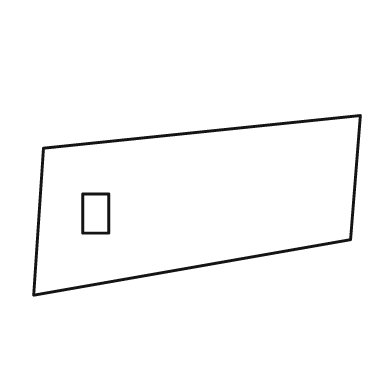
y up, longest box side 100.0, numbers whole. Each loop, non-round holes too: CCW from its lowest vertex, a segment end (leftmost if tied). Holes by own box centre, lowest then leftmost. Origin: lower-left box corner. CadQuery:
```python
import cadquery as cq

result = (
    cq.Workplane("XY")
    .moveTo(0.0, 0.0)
    .lineTo(97.0, 17.0)
    .lineTo(100.0, 55.0)
    .lineTo(3.0, 45.0)
    .close()
    .moveTo(15.0, 19.0)
    .lineTo(23.0, 19.0)
    .lineTo(23.0, 31.0)
    .lineTo(15.0, 31.0)
    .close()
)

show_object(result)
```